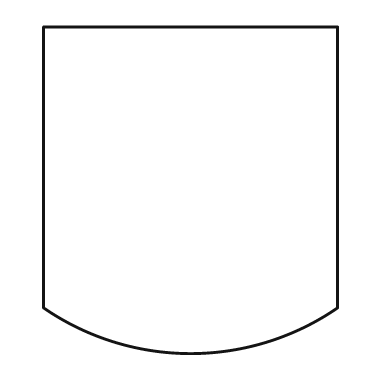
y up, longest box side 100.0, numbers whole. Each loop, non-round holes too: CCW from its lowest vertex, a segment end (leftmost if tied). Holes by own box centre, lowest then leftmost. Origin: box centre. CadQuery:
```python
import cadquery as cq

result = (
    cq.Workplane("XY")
    .moveTo(-45.0, -36.0)
    .threePointArc((0.0, -50.0), (45.0, -36.0))
    .lineTo(45.0, 50.0)
    .lineTo(-45.0, 50.0)
    .close()
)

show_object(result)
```